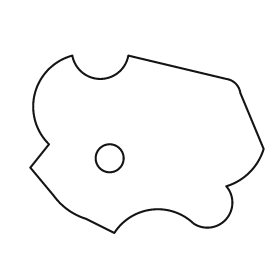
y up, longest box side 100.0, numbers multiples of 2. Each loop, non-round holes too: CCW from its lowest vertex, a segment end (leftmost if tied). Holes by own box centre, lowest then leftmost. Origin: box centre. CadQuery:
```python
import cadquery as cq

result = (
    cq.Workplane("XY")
    .moveTo(-14.0, -38.0)
    .threePointArc((2.0, -28.0), (20.0, -34.0))
    .threePointArc((34.0, -32.0), (34.0, -18.0))
    .threePointArc((44.0, -12.0), (50.0, -2.0))
    .lineTo(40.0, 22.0)
    .threePointArc((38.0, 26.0), (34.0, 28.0))
    .lineTo(-8.0, 38.0)
    .threePointArc((-20.0, 28.0), (-32.0, 38.0))
    .threePointArc((-48.0, 22.0), (-42.0, 0.0))
    .lineTo(-50.0, -10.0)
    .lineTo(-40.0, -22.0)
    .threePointArc((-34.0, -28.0), (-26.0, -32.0))
    .close()
    .moveTo(-16.0, -6.0)
    .circle(6.0)
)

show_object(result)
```